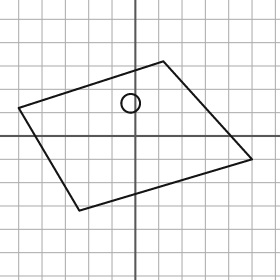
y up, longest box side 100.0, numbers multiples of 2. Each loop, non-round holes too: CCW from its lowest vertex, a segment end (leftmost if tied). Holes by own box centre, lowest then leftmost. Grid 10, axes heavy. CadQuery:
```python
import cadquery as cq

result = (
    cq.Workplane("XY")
    .moveTo(-24.0, -32.0)
    .lineTo(50.0, -10.0)
    .lineTo(12.0, 32.0)
    .lineTo(-50.0, 12.0)
    .close()
    .moveTo(-2.0, 14.0)
    .circle(4.0)
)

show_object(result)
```